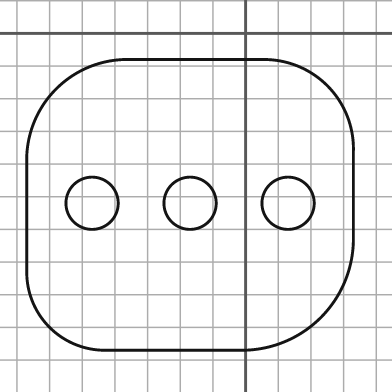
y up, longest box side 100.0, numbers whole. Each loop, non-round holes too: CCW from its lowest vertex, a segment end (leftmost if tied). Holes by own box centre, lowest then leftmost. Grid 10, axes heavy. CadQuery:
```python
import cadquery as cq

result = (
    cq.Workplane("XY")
    .moveTo(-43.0, -97.0)
    .lineTo(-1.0, -97.0)
    .threePointArc((23.0, -87.0), (33.0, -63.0))
    .lineTo(33.0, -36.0)
    .threePointArc((25.0, -16.0), (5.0, -8.0))
    .lineTo(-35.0, -8.0)
    .threePointArc((-58.0, -17.0), (-67.0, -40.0))
    .lineTo(-67.0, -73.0)
    .threePointArc((-60.0, -90.0), (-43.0, -97.0))
    .close()
    .moveTo(-47.0, -52.0)
    .circle(8.0)
    .moveTo(-17.0, -52.0)
    .circle(8.0)
    .moveTo(13.0, -52.0)
    .circle(8.0)
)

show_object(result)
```